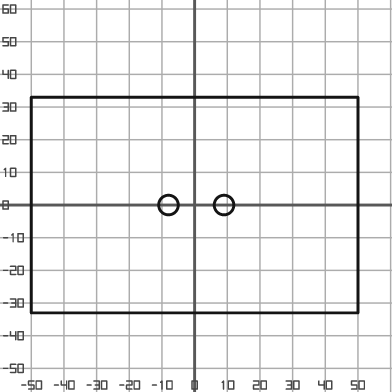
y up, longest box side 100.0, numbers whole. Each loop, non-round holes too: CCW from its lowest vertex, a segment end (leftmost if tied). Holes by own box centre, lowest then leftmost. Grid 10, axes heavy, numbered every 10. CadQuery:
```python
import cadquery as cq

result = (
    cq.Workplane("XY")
    .moveTo(-50.0, -33.0)
    .lineTo(50.0, -33.0)
    .lineTo(50.0, 33.0)
    .lineTo(-50.0, 33.0)
    .close()
    .moveTo(-8.0, 0.0)
    .circle(3.0)
    .moveTo(9.0, 0.0)
    .circle(3.0)
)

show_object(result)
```